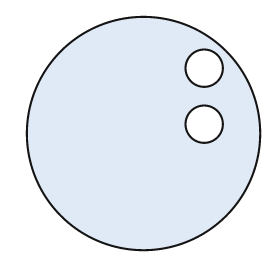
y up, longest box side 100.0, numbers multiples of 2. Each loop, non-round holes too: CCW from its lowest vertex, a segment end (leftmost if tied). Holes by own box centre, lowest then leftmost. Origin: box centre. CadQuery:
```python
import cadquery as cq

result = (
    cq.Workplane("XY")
    .moveTo(0.0, 0.0)
    .circle(50.0)
    .moveTo(26.0, 4.0)
    .circle(8.0)
    .moveTo(26.0, 28.0)
    .circle(8.0)
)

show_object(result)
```